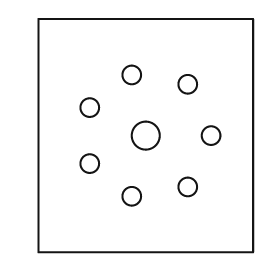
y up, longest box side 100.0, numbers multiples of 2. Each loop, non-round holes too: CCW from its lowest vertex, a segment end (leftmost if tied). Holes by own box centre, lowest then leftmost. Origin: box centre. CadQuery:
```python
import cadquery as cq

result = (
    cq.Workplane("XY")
    .moveTo(-46.0, -50.0)
    .lineTo(46.0, -50.0)
    .lineTo(46.0, 50.0)
    .lineTo(-46.0, 50.0)
    .close()
    .moveTo(-6.0, -26.0)
    .circle(4.0)
    .moveTo(18.0, -22.0)
    .circle(4.0)
    .moveTo(-24.0, -12.0)
    .circle(4.0)
    .moveTo(0.0, 0.0)
    .circle(6.0)
    .moveTo(28.0, 0.0)
    .circle(4.0)
    .moveTo(-24.0, 12.0)
    .circle(4.0)
    .moveTo(18.0, 22.0)
    .circle(4.0)
    .moveTo(-6.0, 26.0)
    .circle(4.0)
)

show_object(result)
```